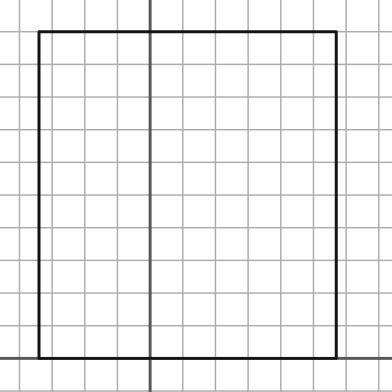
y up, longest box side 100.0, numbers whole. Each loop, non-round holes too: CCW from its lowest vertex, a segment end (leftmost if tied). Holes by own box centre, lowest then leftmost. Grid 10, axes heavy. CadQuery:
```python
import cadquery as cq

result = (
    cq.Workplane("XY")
    .moveTo(-34.0, 0.0)
    .lineTo(57.0, 0.0)
    .lineTo(57.0, 100.0)
    .lineTo(-34.0, 100.0)
    .close()
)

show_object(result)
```